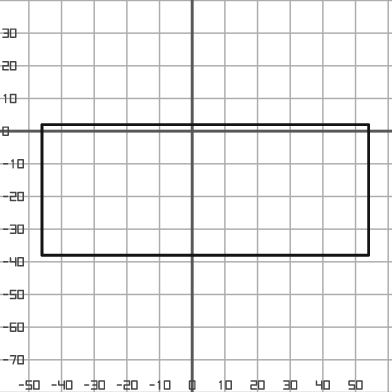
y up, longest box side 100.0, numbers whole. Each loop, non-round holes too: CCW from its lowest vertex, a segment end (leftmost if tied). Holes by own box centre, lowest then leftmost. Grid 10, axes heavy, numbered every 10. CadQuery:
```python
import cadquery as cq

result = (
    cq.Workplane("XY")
    .moveTo(-46.0, -38.0)
    .lineTo(54.0, -38.0)
    .lineTo(54.0, 2.0)
    .lineTo(-46.0, 2.0)
    .close()
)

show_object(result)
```